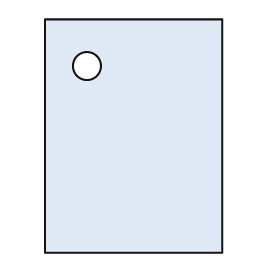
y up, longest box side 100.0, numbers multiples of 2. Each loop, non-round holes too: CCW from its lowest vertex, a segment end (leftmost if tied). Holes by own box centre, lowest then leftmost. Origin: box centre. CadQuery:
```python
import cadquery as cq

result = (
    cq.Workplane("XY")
    .moveTo(-38.0, -50.0)
    .lineTo(38.0, -50.0)
    .lineTo(38.0, 50.0)
    .lineTo(-38.0, 50.0)
    .close()
    .moveTo(-20.0, 30.0)
    .circle(6.0)
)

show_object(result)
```